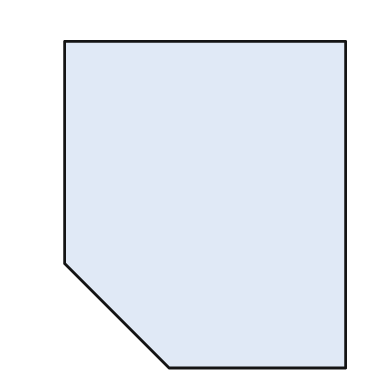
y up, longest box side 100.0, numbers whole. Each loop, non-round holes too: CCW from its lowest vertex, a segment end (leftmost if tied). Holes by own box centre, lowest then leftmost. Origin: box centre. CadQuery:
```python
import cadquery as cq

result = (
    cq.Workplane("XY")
    .moveTo(-11.0, -50.0)
    .lineTo(43.0, -50.0)
    .lineTo(43.0, 50.0)
    .lineTo(-43.0, 50.0)
    .lineTo(-43.0, -18.0)
    .close()
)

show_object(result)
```